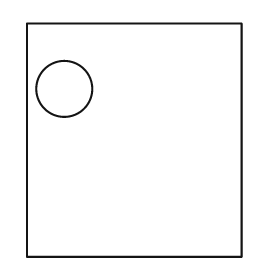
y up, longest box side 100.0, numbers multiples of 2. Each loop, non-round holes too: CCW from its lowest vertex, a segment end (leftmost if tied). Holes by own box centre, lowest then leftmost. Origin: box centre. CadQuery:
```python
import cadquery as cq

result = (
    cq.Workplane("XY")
    .moveTo(-46.0, -50.0)
    .lineTo(46.0, -50.0)
    .lineTo(46.0, 50.0)
    .lineTo(-46.0, 50.0)
    .close()
    .moveTo(-30.0, 22.0)
    .circle(12.0)
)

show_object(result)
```